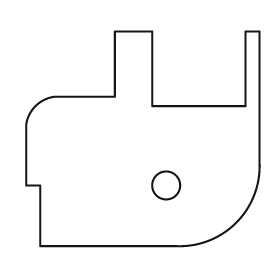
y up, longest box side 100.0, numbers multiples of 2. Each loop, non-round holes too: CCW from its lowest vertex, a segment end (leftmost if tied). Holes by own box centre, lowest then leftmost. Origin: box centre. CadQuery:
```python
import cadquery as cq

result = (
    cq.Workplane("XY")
    .moveTo(-44.0, -46.0)
    .lineTo(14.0, -46.0)
    .threePointArc((40.0, -36.0), (50.0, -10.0))
    .lineTo(50.0, 46.0)
    .lineTo(44.0, 46.0)
    .lineTo(44.0, 14.0)
    .lineTo(4.0, 14.0)
    .lineTo(4.0, 46.0)
    .lineTo(-12.0, 46.0)
    .lineTo(-12.0, 18.0)
    .lineTo(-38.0, 18.0)
    .threePointArc((-46.0, 14.0), (-50.0, 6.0))
    .lineTo(-50.0, -20.0)
    .lineTo(-44.0, -20.0)
    .close()
    .moveTo(10.0, -20.0)
    .circle(6.0)
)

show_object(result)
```